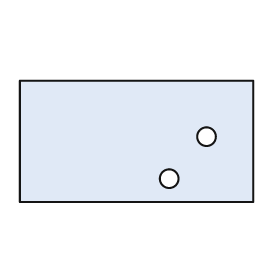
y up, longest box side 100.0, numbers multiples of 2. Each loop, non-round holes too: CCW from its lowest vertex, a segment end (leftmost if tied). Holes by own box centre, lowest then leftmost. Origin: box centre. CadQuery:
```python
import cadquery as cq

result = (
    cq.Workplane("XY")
    .moveTo(-50.0, -26.0)
    .lineTo(50.0, -26.0)
    .lineTo(50.0, 26.0)
    .lineTo(-50.0, 26.0)
    .close()
    .moveTo(14.0, -16.0)
    .circle(4.0)
    .moveTo(30.0, 2.0)
    .circle(4.0)
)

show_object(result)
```